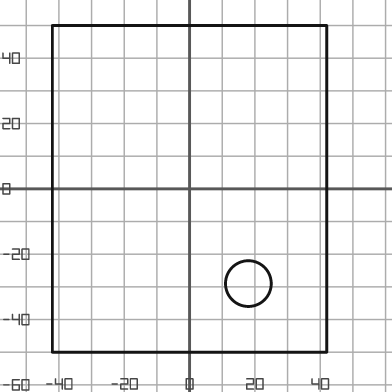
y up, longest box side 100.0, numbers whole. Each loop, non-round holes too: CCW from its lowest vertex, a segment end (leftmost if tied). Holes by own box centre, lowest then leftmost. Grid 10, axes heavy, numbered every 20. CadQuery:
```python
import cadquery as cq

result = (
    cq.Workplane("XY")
    .moveTo(-42.0, -50.0)
    .lineTo(42.0, -50.0)
    .lineTo(42.0, 50.0)
    .lineTo(-42.0, 50.0)
    .close()
    .moveTo(18.0, -29.0)
    .circle(7.0)
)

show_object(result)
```